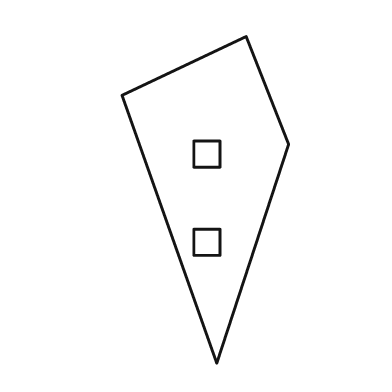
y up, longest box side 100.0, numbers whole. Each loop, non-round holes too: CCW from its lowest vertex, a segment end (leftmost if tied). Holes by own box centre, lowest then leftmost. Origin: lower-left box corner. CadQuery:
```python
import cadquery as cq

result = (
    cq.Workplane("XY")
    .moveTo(29.0, 0.0)
    .lineTo(51.0, 67.0)
    .lineTo(38.0, 100.0)
    .lineTo(0.0, 82.0)
    .close()
    .moveTo(22.0, 33.0)
    .lineTo(30.0, 33.0)
    .lineTo(30.0, 41.0)
    .lineTo(22.0, 41.0)
    .close()
    .moveTo(22.0, 60.0)
    .lineTo(30.0, 60.0)
    .lineTo(30.0, 68.0)
    .lineTo(22.0, 68.0)
    .close()
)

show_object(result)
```